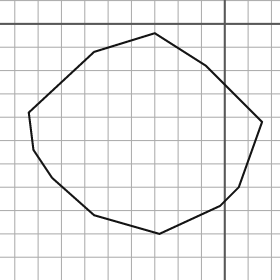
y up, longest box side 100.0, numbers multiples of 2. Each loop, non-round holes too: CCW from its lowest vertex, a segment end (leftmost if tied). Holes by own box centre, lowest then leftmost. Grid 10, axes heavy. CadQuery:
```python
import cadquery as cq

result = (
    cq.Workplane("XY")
    .moveTo(-28.0, -90.0)
    .lineTo(-2.0, -78.0)
    .lineTo(6.0, -70.0)
    .lineTo(16.0, -42.0)
    .lineTo(-8.0, -18.0)
    .lineTo(-30.0, -4.0)
    .lineTo(-56.0, -12.0)
    .lineTo(-84.0, -38.0)
    .lineTo(-82.0, -54.0)
    .lineTo(-74.0, -66.0)
    .lineTo(-56.0, -82.0)
    .close()
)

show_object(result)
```